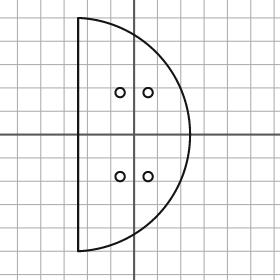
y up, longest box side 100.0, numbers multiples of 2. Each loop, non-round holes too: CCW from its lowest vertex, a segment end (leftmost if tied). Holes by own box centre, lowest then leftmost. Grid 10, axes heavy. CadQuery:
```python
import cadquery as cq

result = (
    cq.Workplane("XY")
    .moveTo(-24.0, -50.0)
    .threePointArc((24.0, 0.0), (-24.0, 50.0))
    .close()
    .moveTo(-6.0, -18.0)
    .circle(2.0)
    .moveTo(6.0, -18.0)
    .circle(2.0)
    .moveTo(-6.0, 18.0)
    .circle(2.0)
    .moveTo(6.0, 18.0)
    .circle(2.0)
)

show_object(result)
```